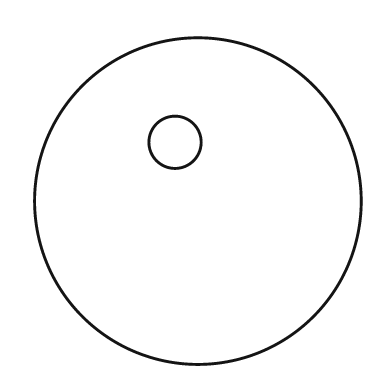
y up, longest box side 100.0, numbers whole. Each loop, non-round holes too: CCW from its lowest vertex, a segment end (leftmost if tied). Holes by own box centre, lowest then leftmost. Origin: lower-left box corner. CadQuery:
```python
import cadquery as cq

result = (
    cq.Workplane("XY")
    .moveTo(50.0, 50.0)
    .circle(50.0)
    .moveTo(43.0, 68.0)
    .circle(8.0)
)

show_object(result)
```